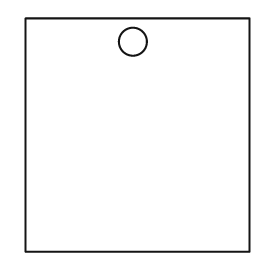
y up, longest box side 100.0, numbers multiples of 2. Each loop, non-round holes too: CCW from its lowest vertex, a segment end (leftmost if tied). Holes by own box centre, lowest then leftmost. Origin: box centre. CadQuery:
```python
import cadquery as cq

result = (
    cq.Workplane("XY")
    .moveTo(-48.0, -50.0)
    .lineTo(48.0, -50.0)
    .lineTo(48.0, 50.0)
    .lineTo(-48.0, 50.0)
    .close()
    .moveTo(-2.0, 40.0)
    .circle(6.0)
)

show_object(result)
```